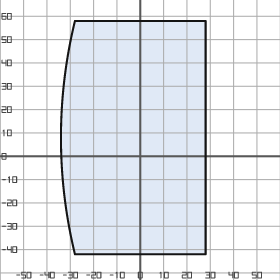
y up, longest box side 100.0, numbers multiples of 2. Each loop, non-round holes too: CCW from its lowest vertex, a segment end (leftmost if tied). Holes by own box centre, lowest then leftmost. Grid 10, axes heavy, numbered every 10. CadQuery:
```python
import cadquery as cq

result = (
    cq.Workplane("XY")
    .moveTo(-28.0, -42.0)
    .lineTo(28.0, -42.0)
    .lineTo(28.0, 58.0)
    .lineTo(-28.0, 58.0)
    .threePointArc((-34.0, 8.0), (-28.0, -42.0))
    .close()
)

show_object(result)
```